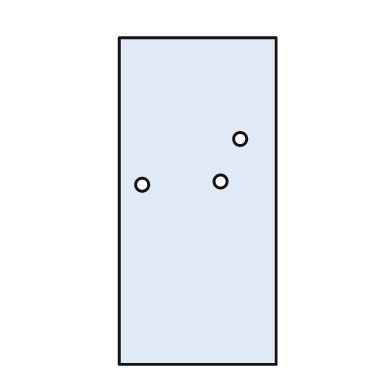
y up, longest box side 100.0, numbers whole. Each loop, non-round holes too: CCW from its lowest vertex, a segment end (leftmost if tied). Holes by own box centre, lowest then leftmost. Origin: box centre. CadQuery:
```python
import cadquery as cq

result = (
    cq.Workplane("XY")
    .moveTo(-24.0, -50.0)
    .lineTo(24.0, -50.0)
    .lineTo(24.0, 50.0)
    .lineTo(-24.0, 50.0)
    .close()
    .moveTo(-17.0, 5.0)
    .circle(2.0)
    .moveTo(7.0, 6.0)
    .circle(2.0)
    .moveTo(13.0, 19.0)
    .circle(2.0)
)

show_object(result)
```